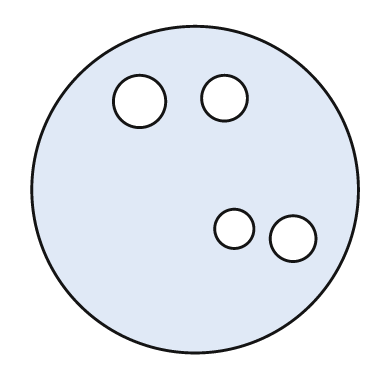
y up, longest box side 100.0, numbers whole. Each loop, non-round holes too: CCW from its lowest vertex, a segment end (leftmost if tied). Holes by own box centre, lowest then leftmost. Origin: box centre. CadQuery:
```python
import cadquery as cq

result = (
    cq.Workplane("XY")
    .moveTo(0.0, 0.0)
    .circle(50.0)
    .moveTo(30.0, -15.0)
    .circle(7.0)
    .moveTo(12.0, -12.0)
    .circle(6.0)
    .moveTo(-17.0, 27.0)
    .circle(8.0)
    .moveTo(9.0, 28.0)
    .circle(7.0)
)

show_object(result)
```